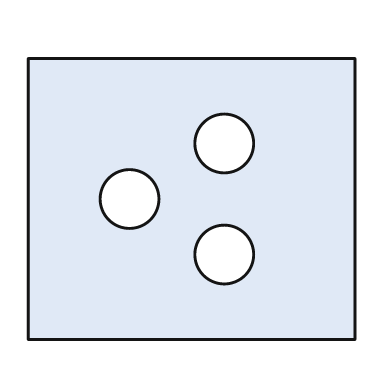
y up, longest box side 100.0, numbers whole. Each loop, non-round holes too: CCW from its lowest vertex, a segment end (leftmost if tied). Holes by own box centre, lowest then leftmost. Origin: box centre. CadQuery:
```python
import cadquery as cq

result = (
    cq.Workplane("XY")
    .moveTo(-50.0, -43.0)
    .lineTo(50.0, -43.0)
    .lineTo(50.0, 43.0)
    .lineTo(-50.0, 43.0)
    .close()
    .moveTo(10.0, -17.0)
    .circle(9.0)
    .moveTo(-19.0, 0.0)
    .circle(9.0)
    .moveTo(10.0, 17.0)
    .circle(9.0)
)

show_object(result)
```